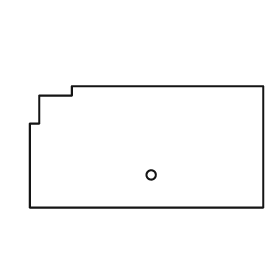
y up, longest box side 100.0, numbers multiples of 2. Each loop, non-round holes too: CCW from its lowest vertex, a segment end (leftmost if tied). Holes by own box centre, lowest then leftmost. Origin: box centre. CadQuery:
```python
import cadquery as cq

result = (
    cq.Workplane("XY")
    .moveTo(-50.0, -26.0)
    .lineTo(50.0, -26.0)
    .lineTo(50.0, 26.0)
    .lineTo(-32.0, 26.0)
    .lineTo(-32.0, 22.0)
    .lineTo(-46.0, 22.0)
    .lineTo(-46.0, 10.0)
    .lineTo(-50.0, 10.0)
    .close()
    .moveTo(2.0, -12.0)
    .circle(2.0)
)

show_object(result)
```